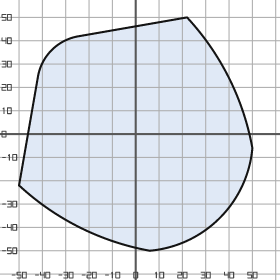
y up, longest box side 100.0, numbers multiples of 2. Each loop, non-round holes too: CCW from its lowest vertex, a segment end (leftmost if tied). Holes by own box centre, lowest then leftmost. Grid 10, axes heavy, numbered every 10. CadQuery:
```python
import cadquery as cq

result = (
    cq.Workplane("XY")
    .moveTo(6.0, -50.0)
    .threePointArc((36.0, -36.0), (50.0, -6.0))
    .threePointArc((40.0, 24.0), (22.0, 50.0))
    .lineTo(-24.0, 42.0)
    .threePointArc((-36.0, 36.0), (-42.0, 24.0))
    .lineTo(-50.0, -22.0)
    .threePointArc((-24.0, -40.0), (6.0, -50.0))
    .close()
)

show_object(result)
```